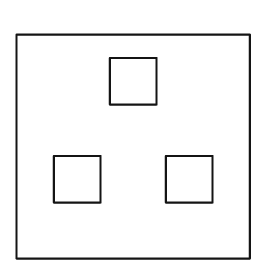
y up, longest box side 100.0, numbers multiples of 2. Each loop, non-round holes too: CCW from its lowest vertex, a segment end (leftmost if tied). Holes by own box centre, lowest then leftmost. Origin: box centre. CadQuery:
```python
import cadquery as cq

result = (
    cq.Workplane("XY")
    .moveTo(-50.0, -48.0)
    .lineTo(50.0, -48.0)
    .lineTo(50.0, 48.0)
    .lineTo(-50.0, 48.0)
    .close()
    .moveTo(-34.0, -24.0)
    .lineTo(-14.0, -24.0)
    .lineTo(-14.0, -4.0)
    .lineTo(-34.0, -4.0)
    .close()
    .moveTo(14.0, -24.0)
    .lineTo(34.0, -24.0)
    .lineTo(34.0, -4.0)
    .lineTo(14.0, -4.0)
    .close()
    .moveTo(-10.0, 18.0)
    .lineTo(10.0, 18.0)
    .lineTo(10.0, 38.0)
    .lineTo(-10.0, 38.0)
    .close()
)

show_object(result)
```